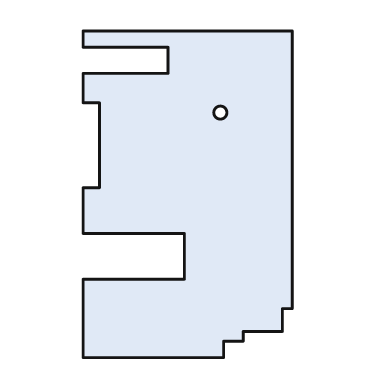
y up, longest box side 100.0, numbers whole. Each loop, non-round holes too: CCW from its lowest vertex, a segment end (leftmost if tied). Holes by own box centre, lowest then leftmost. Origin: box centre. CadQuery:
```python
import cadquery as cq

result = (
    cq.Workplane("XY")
    .moveTo(-32.0, -50.0)
    .lineTo(11.0, -50.0)
    .lineTo(11.0, -45.0)
    .lineTo(17.0, -45.0)
    .lineTo(17.0, -42.0)
    .lineTo(29.0, -42.0)
    .lineTo(29.0, -35.0)
    .lineTo(32.0, -35.0)
    .lineTo(32.0, 50.0)
    .lineTo(-32.0, 50.0)
    .lineTo(-32.0, 45.0)
    .lineTo(-6.0, 45.0)
    .lineTo(-6.0, 37.0)
    .lineTo(-32.0, 37.0)
    .lineTo(-32.0, 28.0)
    .lineTo(-27.0, 28.0)
    .lineTo(-27.0, 2.0)
    .lineTo(-32.0, 2.0)
    .lineTo(-32.0, -12.0)
    .lineTo(-1.0, -12.0)
    .lineTo(-1.0, -26.0)
    .lineTo(-32.0, -26.0)
    .close()
    .moveTo(10.0, 25.0)
    .circle(2.0)
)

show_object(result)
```